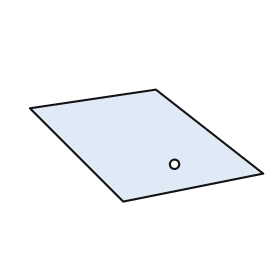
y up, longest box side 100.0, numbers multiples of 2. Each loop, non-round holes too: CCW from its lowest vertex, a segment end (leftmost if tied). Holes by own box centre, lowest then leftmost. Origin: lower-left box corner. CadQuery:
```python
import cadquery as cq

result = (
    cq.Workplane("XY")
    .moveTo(40.0, 0.0)
    .lineTo(100.0, 12.0)
    .lineTo(54.0, 48.0)
    .lineTo(0.0, 40.0)
    .close()
    .moveTo(62.0, 16.0)
    .circle(2.0)
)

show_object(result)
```